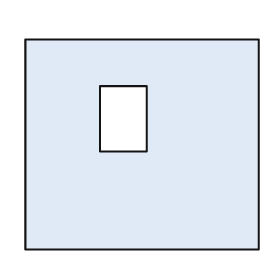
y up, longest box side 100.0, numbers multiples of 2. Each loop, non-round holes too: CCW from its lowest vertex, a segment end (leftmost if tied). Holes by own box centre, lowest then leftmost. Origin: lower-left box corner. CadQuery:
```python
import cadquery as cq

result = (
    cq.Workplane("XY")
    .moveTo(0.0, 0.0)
    .lineTo(100.0, 0.0)
    .lineTo(100.0, 90.0)
    .lineTo(0.0, 90.0)
    .close()
    .moveTo(32.0, 42.0)
    .lineTo(52.0, 42.0)
    .lineTo(52.0, 70.0)
    .lineTo(32.0, 70.0)
    .close()
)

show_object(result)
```